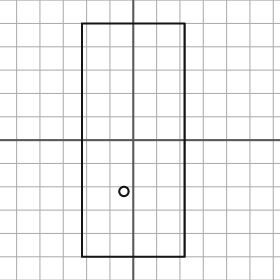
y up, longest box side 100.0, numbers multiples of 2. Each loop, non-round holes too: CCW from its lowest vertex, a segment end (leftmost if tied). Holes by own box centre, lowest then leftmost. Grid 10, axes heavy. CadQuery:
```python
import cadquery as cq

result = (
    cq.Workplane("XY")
    .moveTo(-22.0, -50.0)
    .lineTo(22.0, -50.0)
    .lineTo(22.0, 50.0)
    .lineTo(-22.0, 50.0)
    .close()
    .moveTo(-4.0, -22.0)
    .circle(2.0)
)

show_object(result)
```